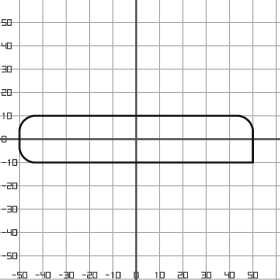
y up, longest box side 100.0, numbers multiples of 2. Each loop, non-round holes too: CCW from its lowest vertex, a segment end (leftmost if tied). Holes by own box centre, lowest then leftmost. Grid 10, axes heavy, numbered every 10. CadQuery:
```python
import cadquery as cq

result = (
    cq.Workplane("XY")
    .moveTo(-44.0, -10.0)
    .lineTo(50.0, -10.0)
    .lineTo(50.0, 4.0)
    .threePointArc((48.0, 8.0), (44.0, 10.0))
    .lineTo(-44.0, 10.0)
    .threePointArc((-48.0, 8.0), (-50.0, 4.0))
    .lineTo(-50.0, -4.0)
    .threePointArc((-48.0, -8.0), (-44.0, -10.0))
    .close()
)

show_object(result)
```